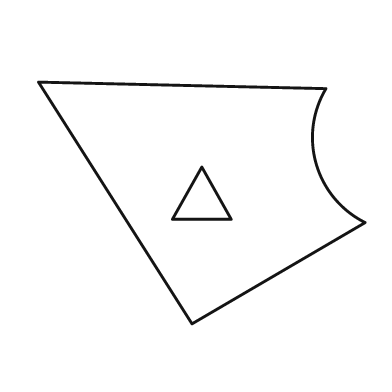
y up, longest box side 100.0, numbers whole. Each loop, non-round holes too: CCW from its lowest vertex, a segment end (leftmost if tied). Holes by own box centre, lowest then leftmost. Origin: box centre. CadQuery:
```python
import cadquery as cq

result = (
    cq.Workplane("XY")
    .moveTo(-3.0, -37.0)
    .lineTo(50.0, -6.0)
    .threePointArc((35.0, 12.0), (38.0, 35.0))
    .lineTo(-50.0, 37.0)
    .close()
    .moveTo(-9.0, -5.0)
    .lineTo(9.0, -5.0)
    .lineTo(0.0, 11.0)
    .close()
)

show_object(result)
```